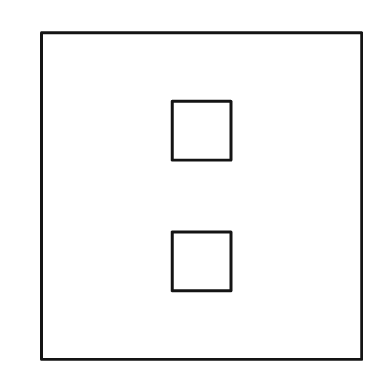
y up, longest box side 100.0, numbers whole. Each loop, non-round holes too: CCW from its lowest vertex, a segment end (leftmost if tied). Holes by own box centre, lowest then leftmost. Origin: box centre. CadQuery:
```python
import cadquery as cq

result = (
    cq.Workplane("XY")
    .moveTo(-49.0, -50.0)
    .lineTo(49.0, -50.0)
    .lineTo(49.0, 50.0)
    .lineTo(-49.0, 50.0)
    .close()
    .moveTo(-9.0, -29.0)
    .lineTo(9.0, -29.0)
    .lineTo(9.0, -11.0)
    .lineTo(-9.0, -11.0)
    .close()
    .moveTo(-9.0, 11.0)
    .lineTo(9.0, 11.0)
    .lineTo(9.0, 29.0)
    .lineTo(-9.0, 29.0)
    .close()
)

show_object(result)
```